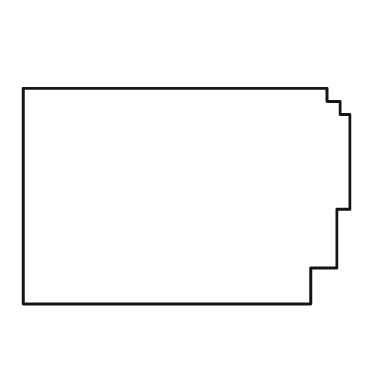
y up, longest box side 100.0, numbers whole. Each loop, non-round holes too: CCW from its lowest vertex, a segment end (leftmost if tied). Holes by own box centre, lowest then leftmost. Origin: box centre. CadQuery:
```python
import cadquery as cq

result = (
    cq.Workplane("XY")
    .moveTo(-50.0, -33.0)
    .lineTo(38.0, -33.0)
    .lineTo(38.0, -22.0)
    .lineTo(46.0, -22.0)
    .lineTo(46.0, -4.0)
    .lineTo(50.0, -4.0)
    .lineTo(50.0, 25.0)
    .lineTo(47.0, 25.0)
    .lineTo(47.0, 29.0)
    .lineTo(43.0, 29.0)
    .lineTo(43.0, 33.0)
    .lineTo(-50.0, 33.0)
    .close()
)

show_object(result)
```